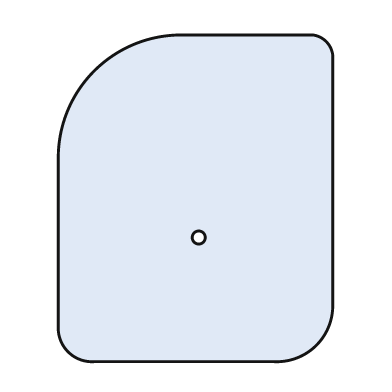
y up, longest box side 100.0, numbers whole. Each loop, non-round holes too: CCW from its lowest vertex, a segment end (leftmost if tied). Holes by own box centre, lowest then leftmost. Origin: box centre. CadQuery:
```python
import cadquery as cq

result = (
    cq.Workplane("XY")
    .moveTo(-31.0, -50.0)
    .lineTo(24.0, -50.0)
    .threePointArc((37.0, -45.0), (42.0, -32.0))
    .lineTo(42.0, 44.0)
    .threePointArc((40.0, 48.0), (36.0, 50.0))
    .lineTo(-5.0, 50.0)
    .threePointArc((-31.0, 39.0), (-42.0, 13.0))
    .lineTo(-42.0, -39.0)
    .threePointArc((-39.0, -47.0), (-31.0, -50.0))
    .close()
    .moveTo(1.0, -12.0)
    .circle(2.0)
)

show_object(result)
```